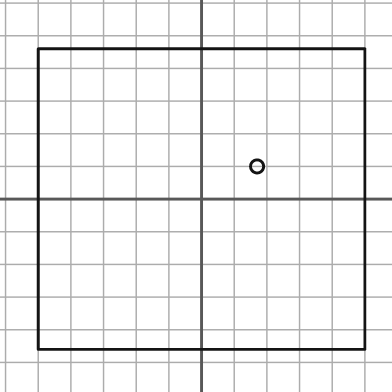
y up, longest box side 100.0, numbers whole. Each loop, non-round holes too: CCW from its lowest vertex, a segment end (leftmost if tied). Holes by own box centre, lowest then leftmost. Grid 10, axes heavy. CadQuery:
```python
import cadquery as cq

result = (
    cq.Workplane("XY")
    .moveTo(-50.0, -46.0)
    .lineTo(50.0, -46.0)
    .lineTo(50.0, 46.0)
    .lineTo(-50.0, 46.0)
    .close()
    .moveTo(17.0, 10.0)
    .circle(2.0)
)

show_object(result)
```